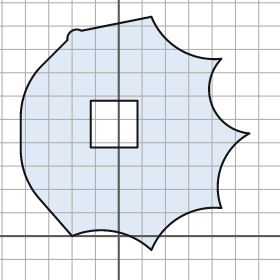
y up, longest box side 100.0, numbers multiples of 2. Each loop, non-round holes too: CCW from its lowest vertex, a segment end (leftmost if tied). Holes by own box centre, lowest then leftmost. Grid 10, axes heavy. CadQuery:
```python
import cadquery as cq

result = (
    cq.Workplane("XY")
    .moveTo(14.0, -6.0)
    .threePointArc((26.0, 8.0), (44.0, 12.0))
    .threePointArc((44.0, 30.0), (56.0, 44.0))
    .threePointArc((40.0, 56.0), (44.0, 76.0))
    .threePointArc((26.0, 80.0), (14.0, 94.0))
    .lineTo(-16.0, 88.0)
    .threePointArc((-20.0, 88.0), (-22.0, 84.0))
    .lineTo(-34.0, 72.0)
    .threePointArc((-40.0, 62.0), (-42.0, 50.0))
    .lineTo(-42.0, 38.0)
    .threePointArc((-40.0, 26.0), (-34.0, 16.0))
    .lineTo(-20.0, 0.0)
    .threePointArc((-2.0, 2.0), (14.0, -6.0))
    .close()
    .moveTo(-12.0, 38.0)
    .lineTo(8.0, 38.0)
    .lineTo(8.0, 58.0)
    .lineTo(-12.0, 58.0)
    .close()
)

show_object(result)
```